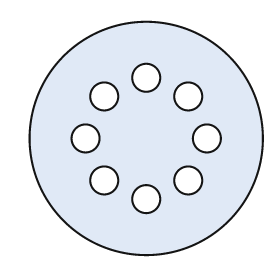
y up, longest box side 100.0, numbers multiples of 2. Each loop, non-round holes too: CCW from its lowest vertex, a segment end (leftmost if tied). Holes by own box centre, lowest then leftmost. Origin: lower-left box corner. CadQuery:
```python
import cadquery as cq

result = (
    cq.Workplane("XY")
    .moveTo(50.0, 50.0)
    .circle(50.0)
    .moveTo(50.0, 24.0)
    .circle(6.0)
    .moveTo(32.0, 32.0)
    .circle(6.0)
    .moveTo(68.0, 32.0)
    .circle(6.0)
    .moveTo(24.0, 50.0)
    .circle(6.0)
    .moveTo(76.0, 50.0)
    .circle(6.0)
    .moveTo(32.0, 68.0)
    .circle(6.0)
    .moveTo(68.0, 68.0)
    .circle(6.0)
    .moveTo(50.0, 76.0)
    .circle(6.0)
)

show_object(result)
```